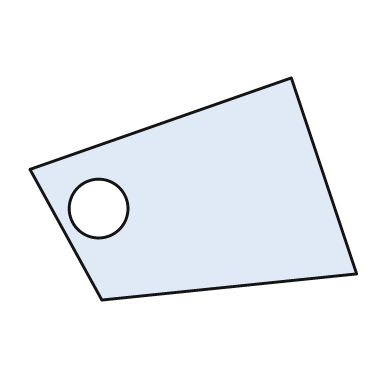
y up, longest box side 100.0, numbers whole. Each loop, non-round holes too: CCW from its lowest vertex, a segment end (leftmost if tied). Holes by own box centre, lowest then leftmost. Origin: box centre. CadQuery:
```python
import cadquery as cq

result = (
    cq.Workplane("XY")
    .moveTo(-28.0, -34.0)
    .lineTo(50.0, -26.0)
    .lineTo(30.0, 34.0)
    .lineTo(-50.0, 6.0)
    .close()
    .moveTo(-29.0, -6.0)
    .circle(9.0)
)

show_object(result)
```